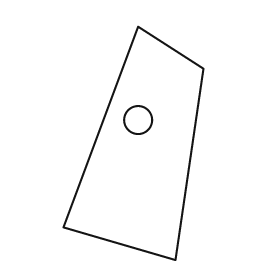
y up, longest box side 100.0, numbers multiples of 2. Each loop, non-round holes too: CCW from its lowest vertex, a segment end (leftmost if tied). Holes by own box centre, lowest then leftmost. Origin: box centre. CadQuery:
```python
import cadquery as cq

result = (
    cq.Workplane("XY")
    .moveTo(18.0, -50.0)
    .lineTo(30.0, 32.0)
    .lineTo(2.0, 50.0)
    .lineTo(-30.0, -36.0)
    .close()
    .moveTo(2.0, 10.0)
    .circle(6.0)
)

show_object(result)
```